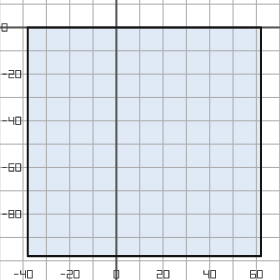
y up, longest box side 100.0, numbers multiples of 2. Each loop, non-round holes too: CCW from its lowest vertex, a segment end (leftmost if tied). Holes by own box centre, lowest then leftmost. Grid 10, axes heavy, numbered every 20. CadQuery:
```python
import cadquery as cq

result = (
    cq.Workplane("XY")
    .moveTo(-38.0, -98.0)
    .lineTo(62.0, -98.0)
    .lineTo(62.0, 0.0)
    .lineTo(-38.0, 0.0)
    .close()
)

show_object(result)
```